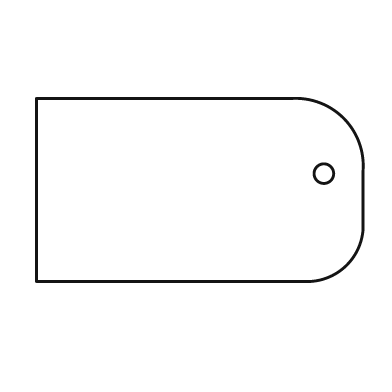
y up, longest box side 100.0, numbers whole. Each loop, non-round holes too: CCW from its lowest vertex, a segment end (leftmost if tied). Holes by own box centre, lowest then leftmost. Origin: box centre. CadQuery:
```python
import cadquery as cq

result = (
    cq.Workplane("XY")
    .moveTo(-50.0, -28.0)
    .lineTo(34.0, -28.0)
    .threePointArc((45.0, -23.0), (50.0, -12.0))
    .lineTo(50.0, 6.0)
    .threePointArc((44.0, 22.0), (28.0, 28.0))
    .lineTo(-50.0, 28.0)
    .close()
    .moveTo(38.0, 5.0)
    .circle(3.0)
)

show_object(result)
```